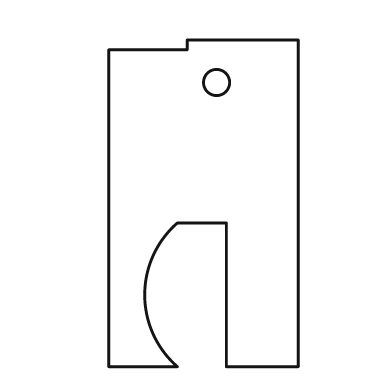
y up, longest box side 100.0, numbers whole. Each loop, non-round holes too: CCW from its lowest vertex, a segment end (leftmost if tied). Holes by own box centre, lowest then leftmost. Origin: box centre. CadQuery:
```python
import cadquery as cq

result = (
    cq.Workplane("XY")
    .moveTo(-29.0, -50.0)
    .lineTo(-8.0, -50.0)
    .threePointArc((-18.0, -28.0), (-8.0, -6.0))
    .lineTo(7.0, -6.0)
    .lineTo(7.0, -50.0)
    .lineTo(29.0, -50.0)
    .lineTo(29.0, 50.0)
    .lineTo(-5.0, 50.0)
    .lineTo(-5.0, 47.0)
    .lineTo(-29.0, 47.0)
    .close()
    .moveTo(4.0, 37.0)
    .circle(4.0)
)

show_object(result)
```